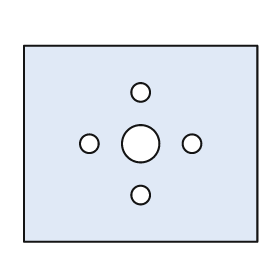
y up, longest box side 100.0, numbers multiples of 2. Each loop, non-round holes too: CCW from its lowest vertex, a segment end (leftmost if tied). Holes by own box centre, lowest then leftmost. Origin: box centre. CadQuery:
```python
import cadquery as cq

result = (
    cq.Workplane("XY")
    .moveTo(-50.0, -42.0)
    .lineTo(50.0, -42.0)
    .lineTo(50.0, 42.0)
    .lineTo(-50.0, 42.0)
    .close()
    .moveTo(0.0, -22.0)
    .circle(4.0)
    .moveTo(-22.0, 0.0)
    .circle(4.0)
    .moveTo(0.0, 0.0)
    .circle(8.0)
    .moveTo(22.0, 0.0)
    .circle(4.0)
    .moveTo(0.0, 22.0)
    .circle(4.0)
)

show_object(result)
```